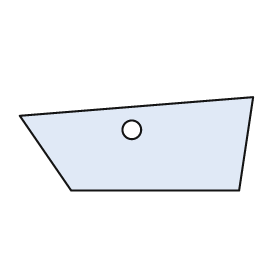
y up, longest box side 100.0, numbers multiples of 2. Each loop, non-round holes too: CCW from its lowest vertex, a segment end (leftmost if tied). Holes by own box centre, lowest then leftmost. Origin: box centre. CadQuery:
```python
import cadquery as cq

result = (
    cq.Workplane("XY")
    .moveTo(-28.0, -20.0)
    .lineTo(44.0, -20.0)
    .lineTo(50.0, 20.0)
    .lineTo(-50.0, 12.0)
    .close()
    .moveTo(-2.0, 6.0)
    .circle(4.0)
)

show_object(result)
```